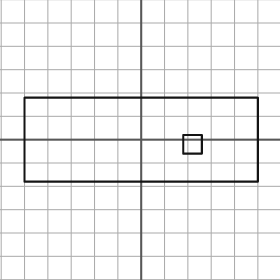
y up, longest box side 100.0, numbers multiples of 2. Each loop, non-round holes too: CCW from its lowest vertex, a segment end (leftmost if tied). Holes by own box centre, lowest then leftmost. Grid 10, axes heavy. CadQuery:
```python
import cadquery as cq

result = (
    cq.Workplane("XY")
    .moveTo(-50.0, -18.0)
    .lineTo(50.0, -18.0)
    .lineTo(50.0, 18.0)
    .lineTo(-50.0, 18.0)
    .close()
    .moveTo(18.0, -6.0)
    .lineTo(26.0, -6.0)
    .lineTo(26.0, 2.0)
    .lineTo(18.0, 2.0)
    .close()
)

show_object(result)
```